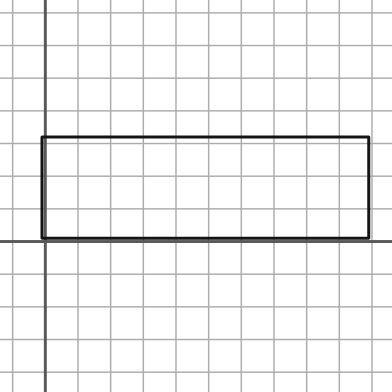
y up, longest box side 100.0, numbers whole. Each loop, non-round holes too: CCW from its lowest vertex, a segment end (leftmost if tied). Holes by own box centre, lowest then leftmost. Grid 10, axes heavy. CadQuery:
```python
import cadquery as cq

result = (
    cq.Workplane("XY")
    .moveTo(-1.0, 1.0)
    .lineTo(99.0, 1.0)
    .lineTo(99.0, 32.0)
    .lineTo(-1.0, 32.0)
    .close()
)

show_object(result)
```